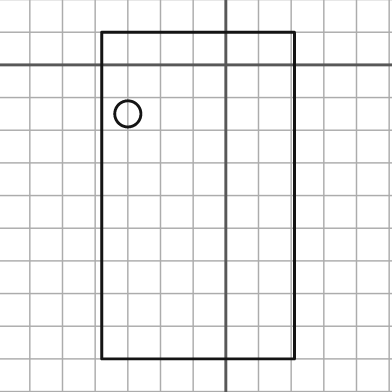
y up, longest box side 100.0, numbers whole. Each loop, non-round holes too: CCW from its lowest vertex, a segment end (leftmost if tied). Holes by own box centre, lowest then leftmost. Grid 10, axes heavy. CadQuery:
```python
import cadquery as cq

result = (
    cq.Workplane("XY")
    .moveTo(-38.0, -90.0)
    .lineTo(21.0, -90.0)
    .lineTo(21.0, 10.0)
    .lineTo(-38.0, 10.0)
    .close()
    .moveTo(-30.0, -15.0)
    .circle(4.0)
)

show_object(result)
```